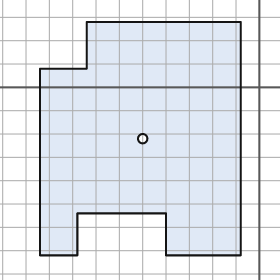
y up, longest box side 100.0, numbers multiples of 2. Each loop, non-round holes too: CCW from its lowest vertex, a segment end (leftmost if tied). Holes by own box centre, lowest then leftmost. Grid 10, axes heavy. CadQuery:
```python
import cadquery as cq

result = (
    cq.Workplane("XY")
    .moveTo(-94.0, -72.0)
    .lineTo(-78.0, -72.0)
    .lineTo(-78.0, -54.0)
    .lineTo(-40.0, -54.0)
    .lineTo(-40.0, -72.0)
    .lineTo(-8.0, -72.0)
    .lineTo(-8.0, 28.0)
    .lineTo(-74.0, 28.0)
    .lineTo(-74.0, 8.0)
    .lineTo(-94.0, 8.0)
    .close()
    .moveTo(-50.0, -22.0)
    .circle(2.0)
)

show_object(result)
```